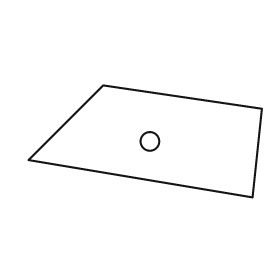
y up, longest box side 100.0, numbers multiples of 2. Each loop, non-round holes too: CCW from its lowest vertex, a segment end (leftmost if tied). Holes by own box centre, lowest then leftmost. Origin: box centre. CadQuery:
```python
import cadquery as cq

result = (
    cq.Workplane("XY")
    .moveTo(46.0, -24.0)
    .lineTo(50.0, 14.0)
    .lineTo(-18.0, 24.0)
    .lineTo(-50.0, -8.0)
    .close()
    .moveTo(2.0, 0.0)
    .circle(4.0)
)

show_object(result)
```